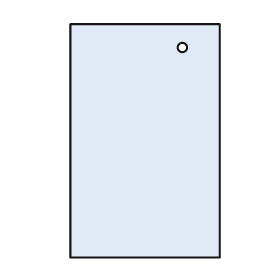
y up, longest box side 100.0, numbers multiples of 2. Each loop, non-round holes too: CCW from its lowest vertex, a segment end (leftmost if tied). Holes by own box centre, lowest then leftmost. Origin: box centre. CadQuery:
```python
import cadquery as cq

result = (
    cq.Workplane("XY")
    .moveTo(-32.0, -50.0)
    .lineTo(32.0, -50.0)
    .lineTo(32.0, 50.0)
    .lineTo(-32.0, 50.0)
    .close()
    .moveTo(16.0, 40.0)
    .circle(2.0)
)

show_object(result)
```